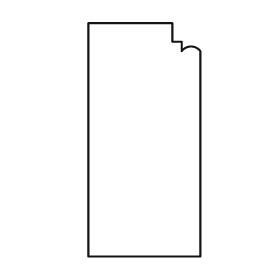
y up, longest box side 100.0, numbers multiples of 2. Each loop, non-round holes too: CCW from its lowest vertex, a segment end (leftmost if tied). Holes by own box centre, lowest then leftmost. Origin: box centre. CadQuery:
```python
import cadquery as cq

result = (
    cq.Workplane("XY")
    .moveTo(-24.0, -50.0)
    .lineTo(24.0, -50.0)
    .lineTo(24.0, 38.0)
    .threePointArc((20.0, 40.0), (16.0, 38.0))
    .lineTo(16.0, 42.0)
    .lineTo(12.0, 42.0)
    .lineTo(12.0, 50.0)
    .lineTo(-24.0, 50.0)
    .close()
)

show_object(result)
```